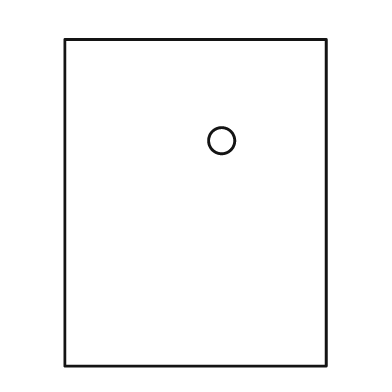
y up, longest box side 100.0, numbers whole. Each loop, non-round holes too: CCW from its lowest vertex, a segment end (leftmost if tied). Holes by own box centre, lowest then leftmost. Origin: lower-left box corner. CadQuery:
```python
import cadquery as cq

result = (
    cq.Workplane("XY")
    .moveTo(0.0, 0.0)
    .lineTo(80.0, 0.0)
    .lineTo(80.0, 100.0)
    .lineTo(0.0, 100.0)
    .close()
    .moveTo(48.0, 69.0)
    .circle(4.0)
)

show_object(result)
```